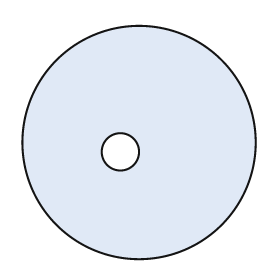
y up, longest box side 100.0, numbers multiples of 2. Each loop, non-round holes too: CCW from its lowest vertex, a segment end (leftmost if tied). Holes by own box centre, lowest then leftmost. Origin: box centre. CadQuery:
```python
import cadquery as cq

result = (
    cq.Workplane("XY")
    .moveTo(0.0, 0.0)
    .circle(50.0)
    .moveTo(-8.0, -4.0)
    .circle(8.0)
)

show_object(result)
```